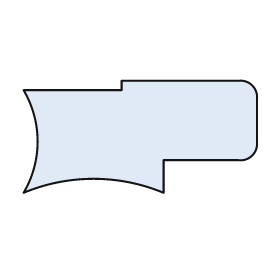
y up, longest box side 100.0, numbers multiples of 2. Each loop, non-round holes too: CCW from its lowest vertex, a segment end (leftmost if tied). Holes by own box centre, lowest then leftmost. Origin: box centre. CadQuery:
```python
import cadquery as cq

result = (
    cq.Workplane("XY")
    .moveTo(-50.0, -24.0)
    .threePointArc((-20.0, -18.0), (10.0, -24.0))
    .lineTo(10.0, -10.0)
    .lineTo(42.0, -10.0)
    .threePointArc((48.0, -8.0), (50.0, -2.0))
    .lineTo(50.0, 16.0)
    .threePointArc((48.0, 22.0), (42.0, 24.0))
    .lineTo(-8.0, 24.0)
    .lineTo(-8.0, 20.0)
    .lineTo(-50.0, 20.0)
    .threePointArc((-44.0, -2.0), (-50.0, -24.0))
    .close()
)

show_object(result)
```